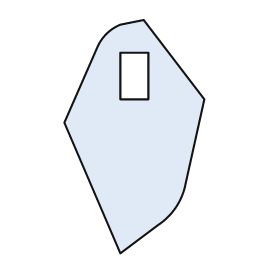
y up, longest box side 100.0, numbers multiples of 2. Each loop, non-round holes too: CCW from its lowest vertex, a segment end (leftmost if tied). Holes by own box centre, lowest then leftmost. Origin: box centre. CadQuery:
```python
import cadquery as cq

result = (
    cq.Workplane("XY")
    .moveTo(-6.0, -50.0)
    .lineTo(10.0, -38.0)
    .threePointArc((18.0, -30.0), (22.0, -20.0))
    .lineTo(30.0, 16.0)
    .lineTo(4.0, 50.0)
    .lineTo(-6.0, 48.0)
    .threePointArc((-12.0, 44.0), (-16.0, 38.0))
    .lineTo(-30.0, 6.0)
    .close()
    .moveTo(-6.0, 16.0)
    .lineTo(6.0, 16.0)
    .lineTo(6.0, 36.0)
    .lineTo(-6.0, 36.0)
    .close()
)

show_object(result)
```